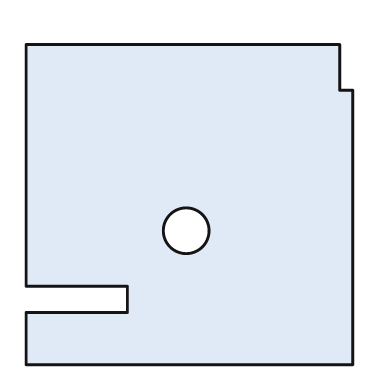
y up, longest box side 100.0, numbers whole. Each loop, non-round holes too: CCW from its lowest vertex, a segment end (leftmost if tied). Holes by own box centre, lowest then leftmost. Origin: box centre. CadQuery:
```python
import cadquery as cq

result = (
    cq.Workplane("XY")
    .moveTo(-50.0, -49.0)
    .lineTo(50.0, -49.0)
    .lineTo(50.0, 35.0)
    .lineTo(46.0, 35.0)
    .lineTo(46.0, 49.0)
    .lineTo(-50.0, 49.0)
    .lineTo(-50.0, -25.0)
    .lineTo(-19.0, -25.0)
    .lineTo(-19.0, -33.0)
    .lineTo(-50.0, -33.0)
    .close()
    .moveTo(-1.0, -8.0)
    .circle(7.0)
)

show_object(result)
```